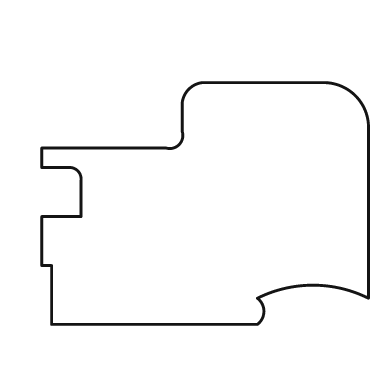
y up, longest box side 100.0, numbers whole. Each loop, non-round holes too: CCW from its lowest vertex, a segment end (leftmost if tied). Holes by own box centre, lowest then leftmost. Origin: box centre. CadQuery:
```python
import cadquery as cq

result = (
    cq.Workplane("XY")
    .moveTo(-47.0, -37.0)
    .lineTo(16.0, -37.0)
    .threePointArc((18.0, -33.0), (16.0, -29.0))
    .threePointArc((33.0, -25.0), (50.0, -29.0))
    .lineTo(50.0, 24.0)
    .threePointArc((46.0, 33.0), (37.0, 37.0))
    .lineTo(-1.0, 37.0)
    .threePointArc((-5.0, 35.0), (-7.0, 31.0))
    .lineTo(-7.0, 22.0)
    .threePointArc((-8.0, 18.0), (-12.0, 17.0))
    .lineTo(-50.0, 17.0)
    .lineTo(-50.0, 11.0)
    .lineTo(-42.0, 11.0)
    .threePointArc((-39.0, 10.0), (-38.0, 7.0))
    .lineTo(-38.0, -4.0)
    .lineTo(-50.0, -4.0)
    .lineTo(-50.0, -19.0)
    .lineTo(-47.0, -19.0)
    .close()
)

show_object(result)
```